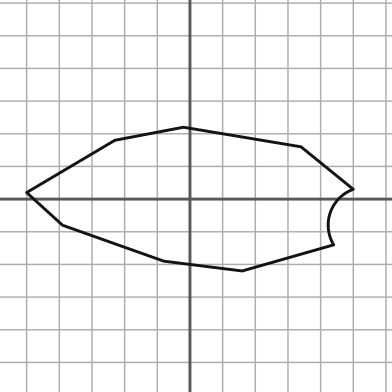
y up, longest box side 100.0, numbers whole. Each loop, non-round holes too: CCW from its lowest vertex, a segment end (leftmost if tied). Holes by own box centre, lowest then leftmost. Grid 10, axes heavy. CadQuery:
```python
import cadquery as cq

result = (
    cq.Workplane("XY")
    .moveTo(16.0, -22.0)
    .lineTo(44.0, -14.0)
    .threePointArc((43.0, -4.0), (50.0, 3.0))
    .lineTo(34.0, 16.0)
    .lineTo(-2.0, 22.0)
    .lineTo(-23.0, 18.0)
    .lineTo(-50.0, 2.0)
    .lineTo(-39.0, -8.0)
    .lineTo(-8.0, -19.0)
    .close()
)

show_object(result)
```